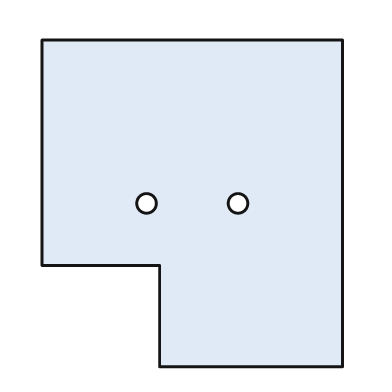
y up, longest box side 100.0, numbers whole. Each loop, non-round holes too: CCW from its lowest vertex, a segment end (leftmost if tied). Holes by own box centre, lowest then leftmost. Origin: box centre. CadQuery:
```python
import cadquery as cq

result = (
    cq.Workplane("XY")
    .moveTo(-10.0, -50.0)
    .lineTo(46.0, -50.0)
    .lineTo(46.0, 50.0)
    .lineTo(-46.0, 50.0)
    .lineTo(-46.0, -19.0)
    .lineTo(-10.0, -19.0)
    .close()
    .moveTo(-14.0, 0.0)
    .circle(3.0)
    .moveTo(14.0, 0.0)
    .circle(3.0)
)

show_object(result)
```